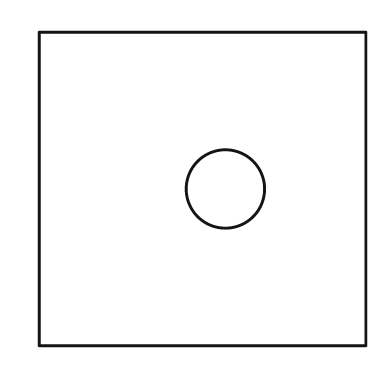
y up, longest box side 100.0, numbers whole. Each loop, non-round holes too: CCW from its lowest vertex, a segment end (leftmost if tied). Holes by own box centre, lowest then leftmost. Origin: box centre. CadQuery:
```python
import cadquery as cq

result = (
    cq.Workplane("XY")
    .moveTo(-50.0, -48.0)
    .lineTo(50.0, -48.0)
    .lineTo(50.0, 48.0)
    .lineTo(-50.0, 48.0)
    .close()
    .moveTo(7.0, 0.0)
    .circle(12.0)
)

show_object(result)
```